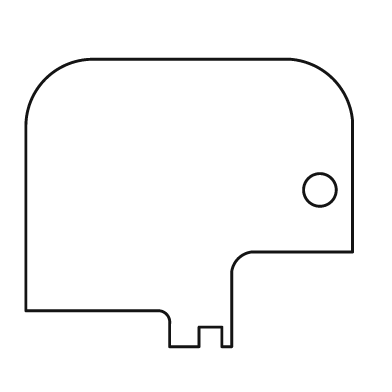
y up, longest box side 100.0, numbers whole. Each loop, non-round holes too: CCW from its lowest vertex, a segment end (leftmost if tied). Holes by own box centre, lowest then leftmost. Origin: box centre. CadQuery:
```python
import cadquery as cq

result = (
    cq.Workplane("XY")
    .moveTo(-6.0, -44.0)
    .lineTo(3.0, -44.0)
    .lineTo(3.0, -38.0)
    .lineTo(10.0, -38.0)
    .lineTo(10.0, -44.0)
    .lineTo(13.0, -44.0)
    .lineTo(13.0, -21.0)
    .threePointArc((15.0, -17.0), (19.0, -15.0))
    .lineTo(50.0, -15.0)
    .lineTo(50.0, 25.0)
    .threePointArc((44.0, 38.0), (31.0, 44.0))
    .lineTo(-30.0, 44.0)
    .threePointArc((-44.0, 38.0), (-50.0, 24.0))
    .lineTo(-50.0, -33.0)
    .lineTo(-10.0, -33.0)
    .threePointArc((-7.0, -34.0), (-6.0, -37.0))
    .close()
    .moveTo(40.0, 4.0)
    .circle(5.0)
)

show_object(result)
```